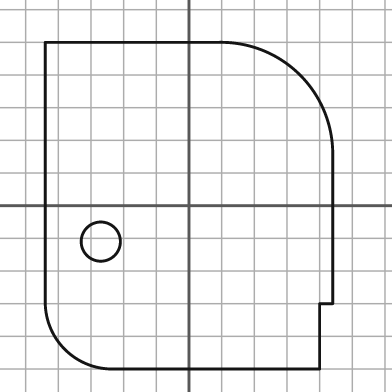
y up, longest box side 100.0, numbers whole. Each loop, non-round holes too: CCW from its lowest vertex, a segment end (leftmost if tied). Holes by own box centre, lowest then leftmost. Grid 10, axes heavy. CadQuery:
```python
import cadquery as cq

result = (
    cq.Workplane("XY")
    .moveTo(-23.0, -50.0)
    .lineTo(40.0, -50.0)
    .lineTo(40.0, -30.0)
    .lineTo(44.0, -30.0)
    .lineTo(44.0, 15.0)
    .threePointArc((34.0, 40.0), (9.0, 50.0))
    .lineTo(-44.0, 50.0)
    .lineTo(-44.0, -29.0)
    .threePointArc((-38.0, -44.0), (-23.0, -50.0))
    .close()
    .moveTo(-27.0, -11.0)
    .circle(6.0)
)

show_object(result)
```